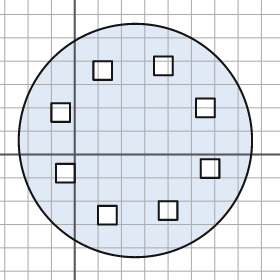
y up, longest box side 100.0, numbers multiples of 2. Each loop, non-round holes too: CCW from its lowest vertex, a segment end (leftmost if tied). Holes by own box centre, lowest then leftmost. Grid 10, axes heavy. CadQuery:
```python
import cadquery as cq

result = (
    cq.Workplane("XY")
    .moveTo(26.0, 6.0)
    .circle(50.0)
    .moveTo(10.0, -30.0)
    .lineTo(18.0, -30.0)
    .lineTo(18.0, -22.0)
    .lineTo(10.0, -22.0)
    .close()
    .moveTo(36.0, -28.0)
    .lineTo(44.0, -28.0)
    .lineTo(44.0, -20.0)
    .lineTo(36.0, -20.0)
    .close()
    .moveTo(-8.0, -12.0)
    .lineTo(0.0, -12.0)
    .lineTo(0.0, -4.0)
    .lineTo(-8.0, -4.0)
    .close()
    .moveTo(54.0, -10.0)
    .lineTo(62.0, -10.0)
    .lineTo(62.0, -2.0)
    .lineTo(54.0, -2.0)
    .close()
    .moveTo(-10.0, 14.0)
    .lineTo(-2.0, 14.0)
    .lineTo(-2.0, 22.0)
    .lineTo(-10.0, 22.0)
    .close()
    .moveTo(52.0, 16.0)
    .lineTo(60.0, 16.0)
    .lineTo(60.0, 24.0)
    .lineTo(52.0, 24.0)
    .close()
    .moveTo(8.0, 32.0)
    .lineTo(16.0, 32.0)
    .lineTo(16.0, 40.0)
    .lineTo(8.0, 40.0)
    .close()
    .moveTo(34.0, 34.0)
    .lineTo(42.0, 34.0)
    .lineTo(42.0, 42.0)
    .lineTo(34.0, 42.0)
    .close()
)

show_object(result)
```